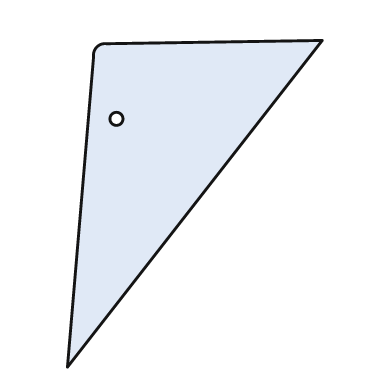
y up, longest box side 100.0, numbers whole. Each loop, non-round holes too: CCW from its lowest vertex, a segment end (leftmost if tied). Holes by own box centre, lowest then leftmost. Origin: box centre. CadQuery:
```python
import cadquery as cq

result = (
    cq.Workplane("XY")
    .moveTo(-39.0, -50.0)
    .lineTo(39.0, 50.0)
    .lineTo(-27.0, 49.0)
    .threePointArc((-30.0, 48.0), (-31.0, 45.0))
    .close()
    .moveTo(-24.0, 26.0)
    .circle(2.0)
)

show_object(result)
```